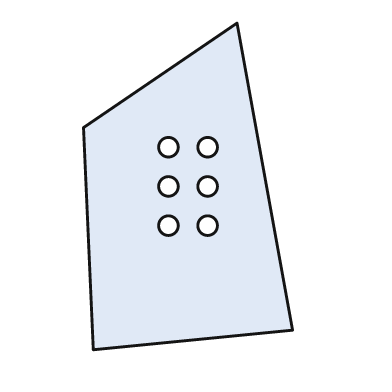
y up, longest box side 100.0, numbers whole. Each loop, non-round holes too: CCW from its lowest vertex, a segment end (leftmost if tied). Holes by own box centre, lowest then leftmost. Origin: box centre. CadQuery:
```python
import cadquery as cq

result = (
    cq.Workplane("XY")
    .moveTo(-29.0, -50.0)
    .lineTo(32.0, -44.0)
    .lineTo(15.0, 50.0)
    .lineTo(-32.0, 18.0)
    .close()
    .moveTo(-6.0, -12.0)
    .circle(3.0)
    .moveTo(6.0, -12.0)
    .circle(3.0)
    .moveTo(-6.0, 0.0)
    .circle(3.0)
    .moveTo(6.0, 0.0)
    .circle(3.0)
    .moveTo(-6.0, 12.0)
    .circle(3.0)
    .moveTo(6.0, 12.0)
    .circle(3.0)
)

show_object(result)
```